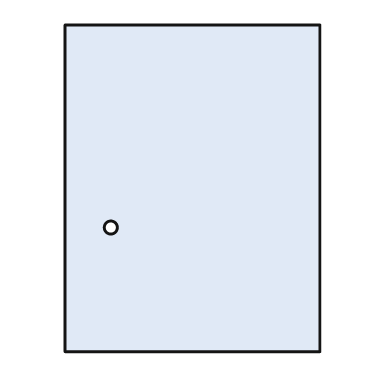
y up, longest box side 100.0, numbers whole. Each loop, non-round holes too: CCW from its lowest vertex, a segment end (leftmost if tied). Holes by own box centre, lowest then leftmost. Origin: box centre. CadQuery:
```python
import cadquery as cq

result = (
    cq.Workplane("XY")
    .moveTo(-39.0, -50.0)
    .lineTo(39.0, -50.0)
    .lineTo(39.0, 50.0)
    .lineTo(-39.0, 50.0)
    .close()
    .moveTo(-25.0, -12.0)
    .circle(2.0)
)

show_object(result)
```